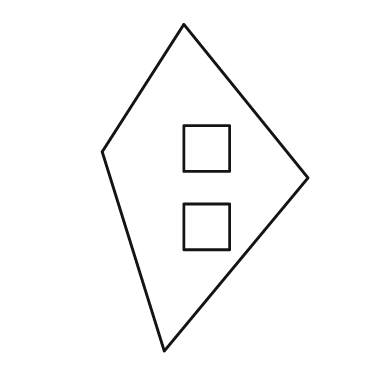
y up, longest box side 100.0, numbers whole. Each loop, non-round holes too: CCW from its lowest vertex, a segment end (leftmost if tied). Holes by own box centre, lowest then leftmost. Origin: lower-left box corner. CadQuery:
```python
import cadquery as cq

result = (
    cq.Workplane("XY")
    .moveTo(19.0, 0.0)
    .lineTo(63.0, 53.0)
    .lineTo(25.0, 100.0)
    .lineTo(0.0, 61.0)
    .close()
    .moveTo(25.0, 31.0)
    .lineTo(39.0, 31.0)
    .lineTo(39.0, 45.0)
    .lineTo(25.0, 45.0)
    .close()
    .moveTo(25.0, 55.0)
    .lineTo(39.0, 55.0)
    .lineTo(39.0, 69.0)
    .lineTo(25.0, 69.0)
    .close()
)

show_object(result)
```